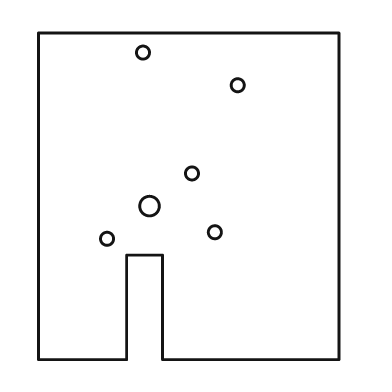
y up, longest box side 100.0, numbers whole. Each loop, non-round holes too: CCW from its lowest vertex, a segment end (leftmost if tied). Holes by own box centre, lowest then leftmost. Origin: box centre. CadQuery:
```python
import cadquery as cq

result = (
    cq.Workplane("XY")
    .moveTo(-46.0, -50.0)
    .lineTo(-19.0, -50.0)
    .lineTo(-19.0, -18.0)
    .lineTo(-8.0, -18.0)
    .lineTo(-8.0, -50.0)
    .lineTo(46.0, -50.0)
    .lineTo(46.0, 50.0)
    .lineTo(-46.0, 50.0)
    .close()
    .moveTo(-25.0, -13.0)
    .circle(2.0)
    .moveTo(8.0, -11.0)
    .circle(2.0)
    .moveTo(-12.0, -3.0)
    .circle(3.0)
    .moveTo(1.0, 7.0)
    .circle(2.0)
    .moveTo(15.0, 34.0)
    .circle(2.0)
    .moveTo(-14.0, 44.0)
    .circle(2.0)
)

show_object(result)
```